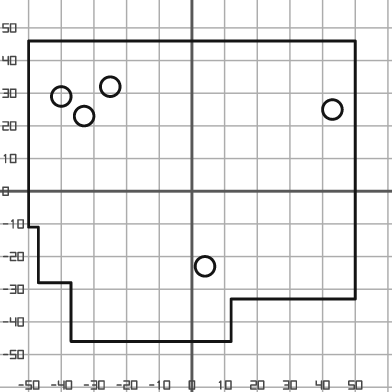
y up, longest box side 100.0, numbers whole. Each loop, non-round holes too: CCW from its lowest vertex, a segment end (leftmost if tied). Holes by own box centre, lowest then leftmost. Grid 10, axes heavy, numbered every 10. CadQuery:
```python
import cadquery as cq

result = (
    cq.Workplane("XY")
    .moveTo(-37.0, -46.0)
    .lineTo(12.0, -46.0)
    .lineTo(12.0, -33.0)
    .lineTo(50.0, -33.0)
    .lineTo(50.0, 46.0)
    .lineTo(-50.0, 46.0)
    .lineTo(-50.0, -11.0)
    .lineTo(-47.0, -11.0)
    .lineTo(-47.0, -28.0)
    .lineTo(-37.0, -28.0)
    .close()
    .moveTo(4.0, -23.0)
    .circle(3.0)
    .moveTo(-33.0, 23.0)
    .circle(3.0)
    .moveTo(43.0, 25.0)
    .circle(3.0)
    .moveTo(-40.0, 29.0)
    .circle(3.0)
    .moveTo(-25.0, 32.0)
    .circle(3.0)
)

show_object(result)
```